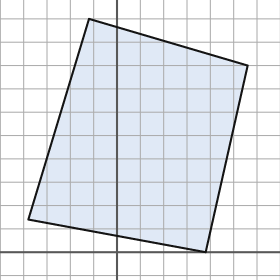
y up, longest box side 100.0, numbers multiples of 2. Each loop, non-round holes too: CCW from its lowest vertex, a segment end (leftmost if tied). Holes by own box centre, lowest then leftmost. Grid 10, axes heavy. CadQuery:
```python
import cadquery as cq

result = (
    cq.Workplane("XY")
    .moveTo(38.0, 0.0)
    .lineTo(56.0, 80.0)
    .lineTo(-12.0, 100.0)
    .lineTo(-38.0, 14.0)
    .close()
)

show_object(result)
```